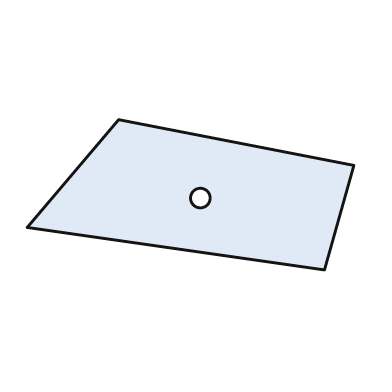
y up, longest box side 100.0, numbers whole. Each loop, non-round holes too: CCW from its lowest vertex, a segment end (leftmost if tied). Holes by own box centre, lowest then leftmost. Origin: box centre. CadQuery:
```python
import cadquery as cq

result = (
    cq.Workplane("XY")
    .moveTo(41.0, -23.0)
    .lineTo(50.0, 9.0)
    .lineTo(-22.0, 23.0)
    .lineTo(-50.0, -10.0)
    .close()
    .moveTo(3.0, -1.0)
    .circle(3.0)
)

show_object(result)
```